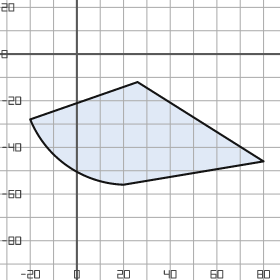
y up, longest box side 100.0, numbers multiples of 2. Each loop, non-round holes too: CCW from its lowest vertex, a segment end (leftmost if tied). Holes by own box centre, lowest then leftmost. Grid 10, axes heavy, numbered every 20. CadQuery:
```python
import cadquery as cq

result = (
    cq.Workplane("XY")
    .moveTo(20.0, -56.0)
    .lineTo(80.0, -46.0)
    .lineTo(26.0, -12.0)
    .lineTo(-20.0, -28.0)
    .threePointArc((-4.0, -48.0), (20.0, -56.0))
    .close()
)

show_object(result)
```